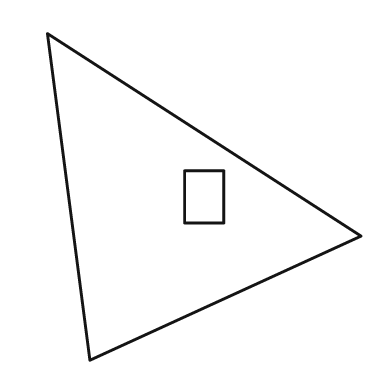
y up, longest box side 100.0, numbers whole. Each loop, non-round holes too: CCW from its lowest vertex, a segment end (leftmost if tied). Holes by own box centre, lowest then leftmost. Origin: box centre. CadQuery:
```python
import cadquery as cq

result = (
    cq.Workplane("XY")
    .moveTo(-35.0, -50.0)
    .lineTo(48.0, -12.0)
    .lineTo(-48.0, 50.0)
    .close()
    .moveTo(-6.0, -8.0)
    .lineTo(6.0, -8.0)
    .lineTo(6.0, 8.0)
    .lineTo(-6.0, 8.0)
    .close()
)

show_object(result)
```